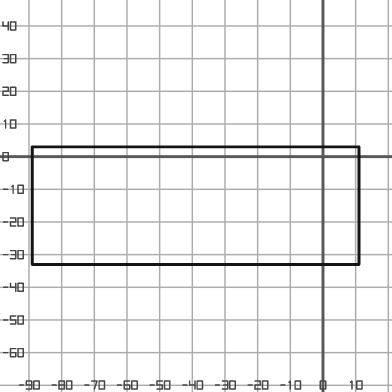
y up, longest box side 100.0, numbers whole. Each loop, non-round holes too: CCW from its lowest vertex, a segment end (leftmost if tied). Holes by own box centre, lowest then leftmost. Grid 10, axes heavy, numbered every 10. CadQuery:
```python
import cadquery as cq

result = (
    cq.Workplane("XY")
    .moveTo(-89.0, -33.0)
    .lineTo(11.0, -33.0)
    .lineTo(11.0, 3.0)
    .lineTo(-89.0, 3.0)
    .close()
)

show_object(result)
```